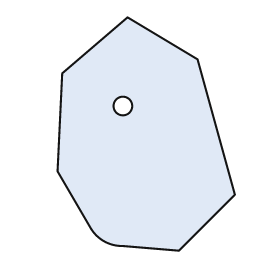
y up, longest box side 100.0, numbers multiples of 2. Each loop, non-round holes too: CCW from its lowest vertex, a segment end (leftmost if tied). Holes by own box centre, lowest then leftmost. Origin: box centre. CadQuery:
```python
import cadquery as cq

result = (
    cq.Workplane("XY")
    .moveTo(14.0, -50.0)
    .lineTo(38.0, -26.0)
    .lineTo(22.0, 32.0)
    .lineTo(-8.0, 50.0)
    .lineTo(-36.0, 26.0)
    .lineTo(-38.0, -16.0)
    .lineTo(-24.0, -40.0)
    .threePointArc((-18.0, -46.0), (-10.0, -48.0))
    .close()
    .moveTo(-10.0, 12.0)
    .circle(4.0)
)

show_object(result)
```